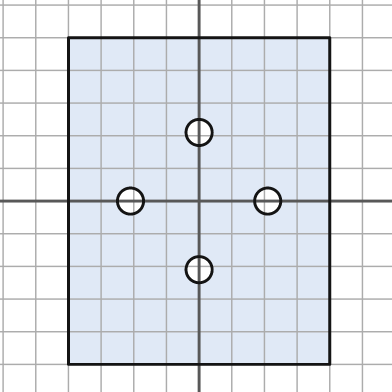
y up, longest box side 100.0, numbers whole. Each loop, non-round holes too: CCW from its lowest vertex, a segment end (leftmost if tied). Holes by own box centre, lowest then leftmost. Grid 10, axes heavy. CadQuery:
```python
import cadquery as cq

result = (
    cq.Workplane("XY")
    .moveTo(-40.0, -50.0)
    .lineTo(40.0, -50.0)
    .lineTo(40.0, 50.0)
    .lineTo(-40.0, 50.0)
    .close()
    .moveTo(0.0, -21.0)
    .circle(4.0)
    .moveTo(-21.0, 0.0)
    .circle(4.0)
    .moveTo(21.0, 0.0)
    .circle(4.0)
    .moveTo(0.0, 21.0)
    .circle(4.0)
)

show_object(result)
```